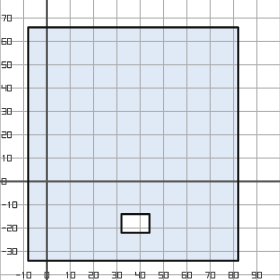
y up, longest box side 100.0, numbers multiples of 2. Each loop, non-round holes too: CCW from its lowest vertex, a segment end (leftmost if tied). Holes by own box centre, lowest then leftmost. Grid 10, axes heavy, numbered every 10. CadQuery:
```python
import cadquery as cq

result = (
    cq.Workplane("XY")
    .moveTo(-8.0, -34.0)
    .lineTo(82.0, -34.0)
    .lineTo(82.0, 66.0)
    .lineTo(-8.0, 66.0)
    .close()
    .moveTo(32.0, -22.0)
    .lineTo(44.0, -22.0)
    .lineTo(44.0, -14.0)
    .lineTo(32.0, -14.0)
    .close()
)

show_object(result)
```